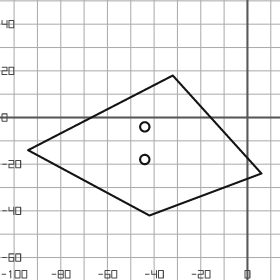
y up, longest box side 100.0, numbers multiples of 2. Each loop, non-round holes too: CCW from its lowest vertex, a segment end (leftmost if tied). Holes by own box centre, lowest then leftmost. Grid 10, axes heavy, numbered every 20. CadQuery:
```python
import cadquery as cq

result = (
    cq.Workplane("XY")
    .moveTo(-42.0, -42.0)
    .lineTo(6.0, -24.0)
    .lineTo(-32.0, 18.0)
    .lineTo(-94.0, -14.0)
    .close()
    .moveTo(-44.0, -18.0)
    .circle(2.0)
    .moveTo(-44.0, -4.0)
    .circle(2.0)
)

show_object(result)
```